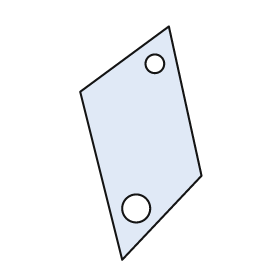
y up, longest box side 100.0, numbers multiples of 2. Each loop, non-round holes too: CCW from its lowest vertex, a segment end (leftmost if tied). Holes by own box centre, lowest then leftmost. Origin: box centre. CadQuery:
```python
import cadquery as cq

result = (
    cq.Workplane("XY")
    .moveTo(-8.0, -50.0)
    .lineTo(26.0, -14.0)
    .lineTo(12.0, 50.0)
    .lineTo(-26.0, 22.0)
    .close()
    .moveTo(-2.0, -28.0)
    .circle(6.0)
    .moveTo(6.0, 34.0)
    .circle(4.0)
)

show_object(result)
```